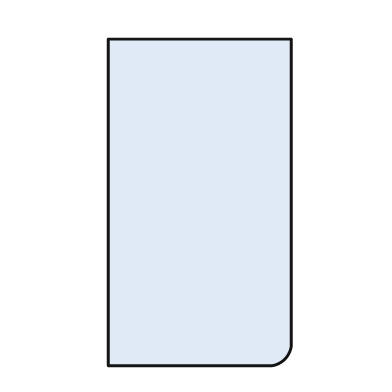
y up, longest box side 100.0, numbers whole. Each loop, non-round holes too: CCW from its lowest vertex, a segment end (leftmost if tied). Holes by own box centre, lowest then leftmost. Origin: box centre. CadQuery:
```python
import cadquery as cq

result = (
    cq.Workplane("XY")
    .moveTo(-28.0, -50.0)
    .lineTo(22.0, -50.0)
    .threePointArc((26.0, -48.0), (28.0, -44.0))
    .lineTo(28.0, 50.0)
    .lineTo(-28.0, 50.0)
    .close()
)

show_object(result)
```